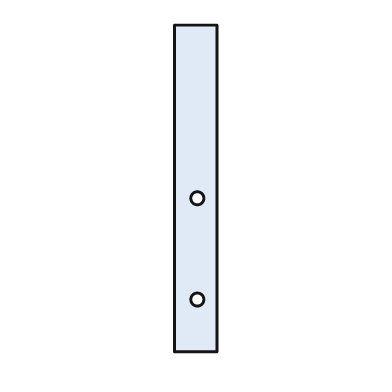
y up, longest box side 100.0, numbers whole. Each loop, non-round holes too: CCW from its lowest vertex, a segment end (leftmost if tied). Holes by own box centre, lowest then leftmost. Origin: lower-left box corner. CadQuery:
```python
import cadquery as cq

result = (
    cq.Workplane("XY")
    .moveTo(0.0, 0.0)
    .lineTo(13.0, 0.0)
    .lineTo(13.0, 100.0)
    .lineTo(0.0, 100.0)
    .close()
    .moveTo(7.0, 16.0)
    .circle(2.0)
    .moveTo(7.0, 47.0)
    .circle(2.0)
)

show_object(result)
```